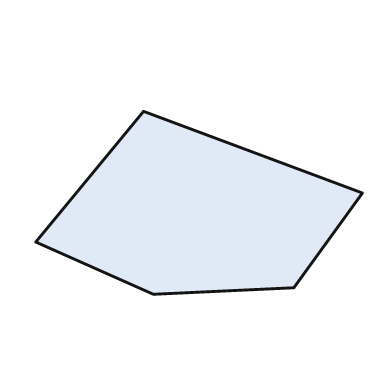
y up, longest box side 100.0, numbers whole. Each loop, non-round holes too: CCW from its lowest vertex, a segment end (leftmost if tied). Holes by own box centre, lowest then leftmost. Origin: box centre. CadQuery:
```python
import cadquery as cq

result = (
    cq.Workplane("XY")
    .moveTo(-14.0, -28.0)
    .lineTo(29.0, -26.0)
    .lineTo(50.0, 3.0)
    .lineTo(-17.0, 28.0)
    .lineTo(-50.0, -12.0)
    .close()
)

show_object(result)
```